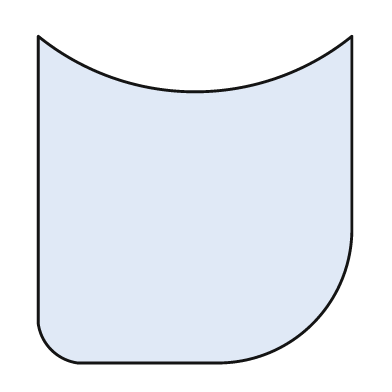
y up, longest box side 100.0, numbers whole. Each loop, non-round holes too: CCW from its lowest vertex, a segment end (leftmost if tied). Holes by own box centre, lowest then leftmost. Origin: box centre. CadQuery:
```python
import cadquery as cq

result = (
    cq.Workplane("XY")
    .moveTo(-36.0, -50.0)
    .lineTo(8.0, -50.0)
    .threePointArc((36.0, -38.0), (48.0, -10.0))
    .lineTo(48.0, 50.0)
    .threePointArc((0.0, 33.0), (-48.0, 50.0))
    .lineTo(-48.0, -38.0)
    .threePointArc((-44.0, -46.0), (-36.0, -50.0))
    .close()
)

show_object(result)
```